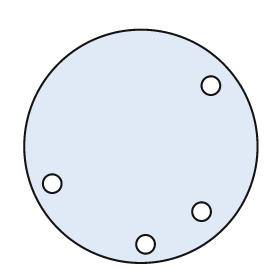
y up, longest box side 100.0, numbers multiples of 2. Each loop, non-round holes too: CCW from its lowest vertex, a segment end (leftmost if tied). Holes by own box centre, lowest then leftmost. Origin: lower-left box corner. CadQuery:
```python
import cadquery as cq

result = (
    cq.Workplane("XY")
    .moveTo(50.0, 50.0)
    .circle(50.0)
    .moveTo(52.0, 8.0)
    .circle(4.0)
    .moveTo(76.0, 22.0)
    .circle(4.0)
    .moveTo(12.0, 34.0)
    .circle(4.0)
    .moveTo(80.0, 76.0)
    .circle(4.0)
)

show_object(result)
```